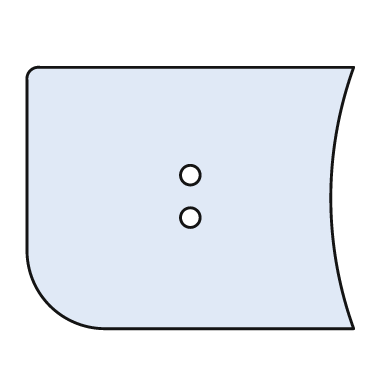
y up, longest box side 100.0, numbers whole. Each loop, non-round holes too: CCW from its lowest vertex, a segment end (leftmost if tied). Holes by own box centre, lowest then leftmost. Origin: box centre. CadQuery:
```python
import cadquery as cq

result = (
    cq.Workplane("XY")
    .moveTo(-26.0, -40.0)
    .lineTo(50.0, -40.0)
    .threePointArc((43.0, 0.0), (50.0, 40.0))
    .lineTo(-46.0, 40.0)
    .threePointArc((-49.0, 39.0), (-50.0, 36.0))
    .lineTo(-50.0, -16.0)
    .threePointArc((-43.0, -33.0), (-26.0, -40.0))
    .close()
    .moveTo(0.0, -6.0)
    .circle(3.0)
    .moveTo(0.0, 7.0)
    .circle(3.0)
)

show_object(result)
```